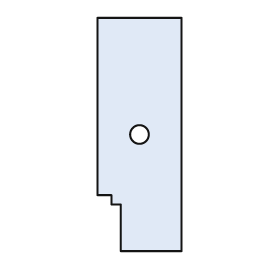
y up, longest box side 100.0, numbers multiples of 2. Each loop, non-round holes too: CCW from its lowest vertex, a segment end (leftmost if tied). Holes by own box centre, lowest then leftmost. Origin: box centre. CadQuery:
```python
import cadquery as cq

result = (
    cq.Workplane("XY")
    .moveTo(-8.0, -50.0)
    .lineTo(18.0, -50.0)
    .lineTo(18.0, 50.0)
    .lineTo(-18.0, 50.0)
    .lineTo(-18.0, -26.0)
    .lineTo(-12.0, -26.0)
    .lineTo(-12.0, -30.0)
    .lineTo(-8.0, -30.0)
    .close()
    .moveTo(0.0, 0.0)
    .circle(4.0)
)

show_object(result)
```